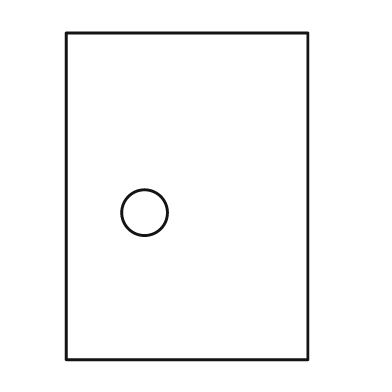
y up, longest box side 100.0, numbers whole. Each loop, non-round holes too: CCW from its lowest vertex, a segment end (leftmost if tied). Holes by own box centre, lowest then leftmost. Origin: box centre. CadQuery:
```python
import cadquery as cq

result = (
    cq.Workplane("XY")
    .moveTo(-37.0, -50.0)
    .lineTo(37.0, -50.0)
    .lineTo(37.0, 50.0)
    .lineTo(-37.0, 50.0)
    .close()
    .moveTo(-13.0, -5.0)
    .circle(7.0)
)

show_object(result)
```